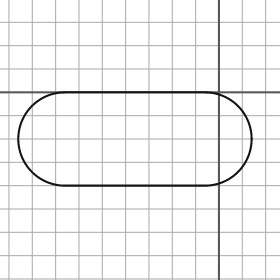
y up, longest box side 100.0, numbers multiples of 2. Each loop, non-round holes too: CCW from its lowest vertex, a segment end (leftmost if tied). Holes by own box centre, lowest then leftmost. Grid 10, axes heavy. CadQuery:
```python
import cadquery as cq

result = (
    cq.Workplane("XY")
    .moveTo(-66.0, -40.0)
    .lineTo(-6.0, -40.0)
    .threePointArc((14.0, -20.0), (-6.0, 0.0))
    .lineTo(-66.0, 0.0)
    .threePointArc((-86.0, -20.0), (-66.0, -40.0))
    .close()
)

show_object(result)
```